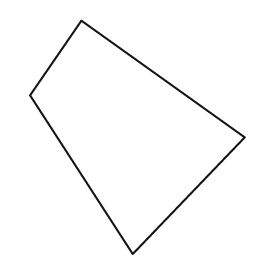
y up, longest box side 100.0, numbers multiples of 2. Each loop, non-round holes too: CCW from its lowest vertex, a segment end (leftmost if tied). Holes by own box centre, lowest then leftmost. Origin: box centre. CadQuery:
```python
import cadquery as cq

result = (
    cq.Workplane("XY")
    .moveTo(-2.0, -50.0)
    .lineTo(46.0, 0.0)
    .lineTo(-24.0, 50.0)
    .lineTo(-46.0, 18.0)
    .close()
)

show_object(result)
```